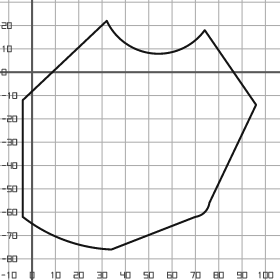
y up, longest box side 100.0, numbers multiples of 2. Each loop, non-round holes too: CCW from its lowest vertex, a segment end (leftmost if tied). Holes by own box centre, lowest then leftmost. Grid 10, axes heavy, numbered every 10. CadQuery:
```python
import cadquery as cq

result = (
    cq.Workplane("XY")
    .moveTo(34.0, -76.0)
    .lineTo(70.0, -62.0)
    .threePointArc((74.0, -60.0), (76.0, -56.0))
    .lineTo(96.0, -14.0)
    .lineTo(74.0, 18.0)
    .threePointArc((52.0, 8.0), (32.0, 22.0))
    .lineTo(-4.0, -12.0)
    .lineTo(-4.0, -62.0)
    .threePointArc((14.0, -72.0), (34.0, -76.0))
    .close()
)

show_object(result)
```